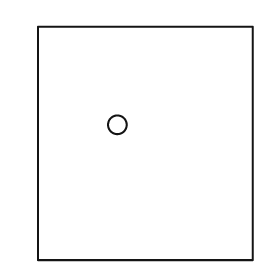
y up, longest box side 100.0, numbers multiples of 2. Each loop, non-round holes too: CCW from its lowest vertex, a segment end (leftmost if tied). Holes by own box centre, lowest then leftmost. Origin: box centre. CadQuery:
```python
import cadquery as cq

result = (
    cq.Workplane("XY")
    .moveTo(-46.0, -50.0)
    .lineTo(46.0, -50.0)
    .lineTo(46.0, 50.0)
    .lineTo(-46.0, 50.0)
    .close()
    .moveTo(-12.0, 8.0)
    .circle(4.0)
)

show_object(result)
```